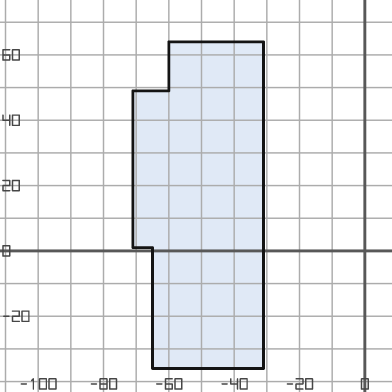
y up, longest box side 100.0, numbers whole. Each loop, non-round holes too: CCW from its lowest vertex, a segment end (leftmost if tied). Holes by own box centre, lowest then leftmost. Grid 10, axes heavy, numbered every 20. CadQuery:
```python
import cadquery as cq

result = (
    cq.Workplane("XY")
    .moveTo(-65.0, -36.0)
    .lineTo(-31.0, -36.0)
    .lineTo(-31.0, 64.0)
    .lineTo(-60.0, 64.0)
    .lineTo(-60.0, 49.0)
    .lineTo(-71.0, 49.0)
    .lineTo(-71.0, 1.0)
    .lineTo(-65.0, 1.0)
    .close()
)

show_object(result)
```